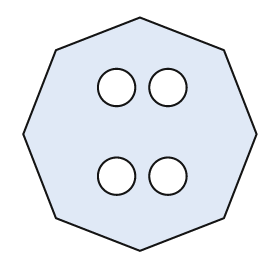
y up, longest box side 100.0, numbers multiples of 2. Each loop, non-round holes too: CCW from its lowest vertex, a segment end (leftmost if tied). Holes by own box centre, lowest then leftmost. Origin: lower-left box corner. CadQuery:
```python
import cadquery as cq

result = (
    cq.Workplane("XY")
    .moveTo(50.0, 0.0)
    .lineTo(86.0, 14.0)
    .lineTo(100.0, 50.0)
    .lineTo(86.0, 86.0)
    .lineTo(50.0, 100.0)
    .lineTo(14.0, 86.0)
    .lineTo(0.0, 50.0)
    .lineTo(14.0, 14.0)
    .close()
    .moveTo(40.0, 32.0)
    .circle(8.0)
    .moveTo(62.0, 32.0)
    .circle(8.0)
    .moveTo(40.0, 70.0)
    .circle(8.0)
    .moveTo(62.0, 70.0)
    .circle(8.0)
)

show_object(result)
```